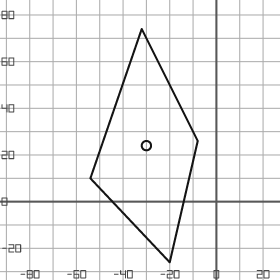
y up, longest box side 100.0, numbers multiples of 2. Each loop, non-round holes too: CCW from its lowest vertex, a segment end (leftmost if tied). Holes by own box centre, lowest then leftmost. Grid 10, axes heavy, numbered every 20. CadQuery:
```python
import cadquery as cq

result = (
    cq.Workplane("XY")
    .moveTo(-20.0, -26.0)
    .lineTo(-8.0, 26.0)
    .lineTo(-32.0, 74.0)
    .lineTo(-54.0, 10.0)
    .close()
    .moveTo(-30.0, 24.0)
    .circle(2.0)
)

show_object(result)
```